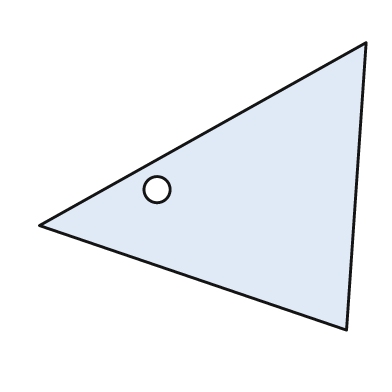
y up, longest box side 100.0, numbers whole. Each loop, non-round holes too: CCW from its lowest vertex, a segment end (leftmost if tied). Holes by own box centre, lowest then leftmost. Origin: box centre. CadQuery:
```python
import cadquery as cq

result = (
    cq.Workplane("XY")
    .moveTo(44.0, -44.0)
    .lineTo(50.0, 44.0)
    .lineTo(-50.0, -12.0)
    .close()
    .moveTo(-14.0, -1.0)
    .circle(4.0)
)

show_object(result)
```